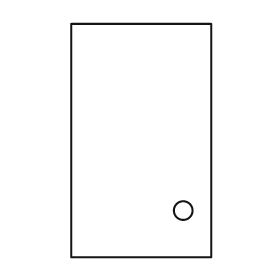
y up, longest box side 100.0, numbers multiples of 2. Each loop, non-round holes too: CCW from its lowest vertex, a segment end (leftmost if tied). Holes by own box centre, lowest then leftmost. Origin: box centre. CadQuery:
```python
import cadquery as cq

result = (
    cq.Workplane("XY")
    .moveTo(-30.0, -50.0)
    .lineTo(30.0, -50.0)
    .lineTo(30.0, 50.0)
    .lineTo(-30.0, 50.0)
    .close()
    .moveTo(18.0, -30.0)
    .circle(4.0)
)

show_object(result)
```